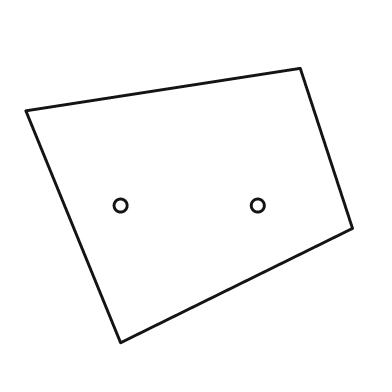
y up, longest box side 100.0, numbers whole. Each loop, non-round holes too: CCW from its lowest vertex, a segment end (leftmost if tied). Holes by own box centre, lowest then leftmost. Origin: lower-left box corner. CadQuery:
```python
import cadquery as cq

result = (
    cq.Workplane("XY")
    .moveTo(29.0, 0.0)
    .lineTo(100.0, 35.0)
    .lineTo(84.0, 84.0)
    .lineTo(0.0, 71.0)
    .close()
    .moveTo(29.0, 42.0)
    .circle(2.0)
    .moveTo(71.0, 42.0)
    .circle(2.0)
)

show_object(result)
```